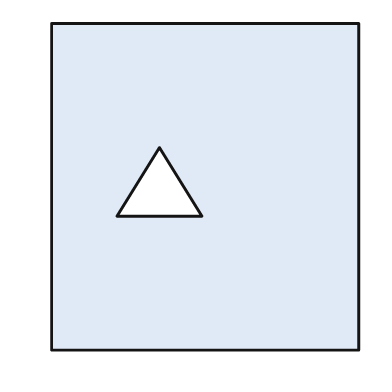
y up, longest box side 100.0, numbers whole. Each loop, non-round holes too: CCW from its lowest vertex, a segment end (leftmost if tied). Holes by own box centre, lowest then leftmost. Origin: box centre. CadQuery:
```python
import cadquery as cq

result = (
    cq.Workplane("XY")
    .moveTo(-47.0, -50.0)
    .lineTo(47.0, -50.0)
    .lineTo(47.0, 50.0)
    .lineTo(-47.0, 50.0)
    .close()
    .moveTo(-27.0, -9.0)
    .lineTo(-1.0, -9.0)
    .lineTo(-14.0, 12.0)
    .close()
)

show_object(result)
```